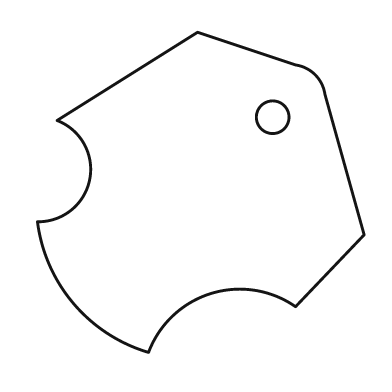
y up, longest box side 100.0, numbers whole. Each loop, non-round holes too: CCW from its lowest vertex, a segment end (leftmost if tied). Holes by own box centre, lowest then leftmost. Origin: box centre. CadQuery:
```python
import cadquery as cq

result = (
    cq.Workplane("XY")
    .moveTo(-16.0, -49.0)
    .threePointArc((3.0, -31.0), (29.0, -35.0))
    .lineTo(50.0, -13.0)
    .lineTo(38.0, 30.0)
    .threePointArc((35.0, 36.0), (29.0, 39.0))
    .lineTo(-1.0, 49.0)
    .lineTo(-44.0, 22.0)
    .threePointArc((-34.0, 4.0), (-50.0, -9.0))
    .threePointArc((-39.0, -34.0), (-16.0, -49.0))
    .close()
    .moveTo(22.0, 23.0)
    .circle(5.0)
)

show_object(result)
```